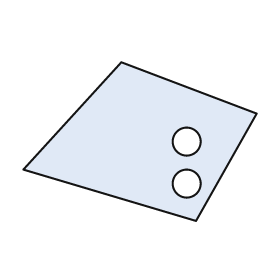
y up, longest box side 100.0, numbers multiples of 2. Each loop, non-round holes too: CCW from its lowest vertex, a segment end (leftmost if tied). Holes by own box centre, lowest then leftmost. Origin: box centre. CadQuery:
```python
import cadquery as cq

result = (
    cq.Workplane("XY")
    .moveTo(24.0, -34.0)
    .lineTo(50.0, 12.0)
    .lineTo(-8.0, 34.0)
    .lineTo(-50.0, -12.0)
    .close()
    .moveTo(20.0, -18.0)
    .circle(6.0)
    .moveTo(20.0, 0.0)
    .circle(6.0)
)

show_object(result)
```